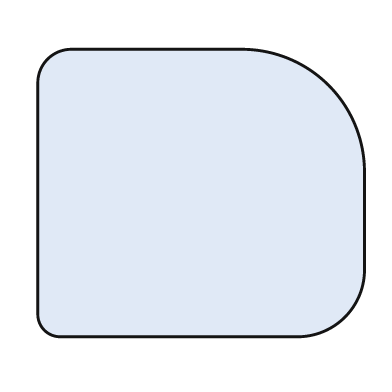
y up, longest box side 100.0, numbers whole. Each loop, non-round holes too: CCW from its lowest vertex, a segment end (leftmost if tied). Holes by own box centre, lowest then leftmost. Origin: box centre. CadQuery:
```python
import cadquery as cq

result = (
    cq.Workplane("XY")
    .moveTo(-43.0, -44.0)
    .lineTo(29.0, -44.0)
    .threePointArc((44.0, -38.0), (50.0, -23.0))
    .lineTo(50.0, 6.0)
    .threePointArc((39.0, 33.0), (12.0, 44.0))
    .lineTo(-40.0, 44.0)
    .threePointArc((-47.0, 41.0), (-50.0, 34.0))
    .lineTo(-50.0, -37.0)
    .threePointArc((-48.0, -42.0), (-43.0, -44.0))
    .close()
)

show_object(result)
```